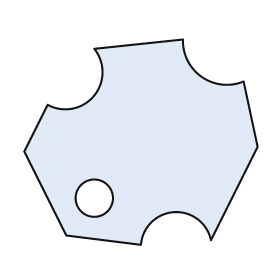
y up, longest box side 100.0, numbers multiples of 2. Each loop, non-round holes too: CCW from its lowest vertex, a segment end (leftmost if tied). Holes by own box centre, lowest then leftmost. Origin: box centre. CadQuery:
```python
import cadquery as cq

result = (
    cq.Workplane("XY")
    .moveTo(0.0, -44.0)
    .threePointArc((14.0, -30.0), (30.0, -42.0))
    .lineTo(50.0, -2.0)
    .lineTo(44.0, 26.0)
    .threePointArc((26.0, 28.0), (18.0, 44.0))
    .lineTo(-20.0, 40.0)
    .threePointArc((-20.0, 20.0), (-40.0, 16.0))
    .lineTo(-50.0, -4.0)
    .lineTo(-32.0, -40.0)
    .close()
    .moveTo(-20.0, -24.0)
    .circle(8.0)
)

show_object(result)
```